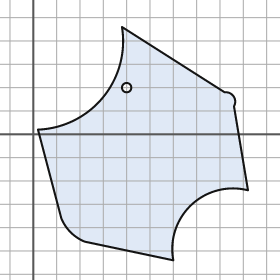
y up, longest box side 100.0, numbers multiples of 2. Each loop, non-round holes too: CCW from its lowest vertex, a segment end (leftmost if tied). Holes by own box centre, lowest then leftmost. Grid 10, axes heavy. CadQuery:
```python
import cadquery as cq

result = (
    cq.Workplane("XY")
    .moveTo(60.0, -54.0)
    .threePointArc((68.0, -30.0), (92.0, -24.0))
    .lineTo(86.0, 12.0)
    .threePointArc((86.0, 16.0), (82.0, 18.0))
    .lineTo(38.0, 46.0)
    .threePointArc((30.0, 16.0), (2.0, 2.0))
    .lineTo(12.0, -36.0)
    .threePointArc((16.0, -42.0), (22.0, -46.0))
    .close()
    .moveTo(40.0, 20.0)
    .circle(2.0)
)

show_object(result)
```